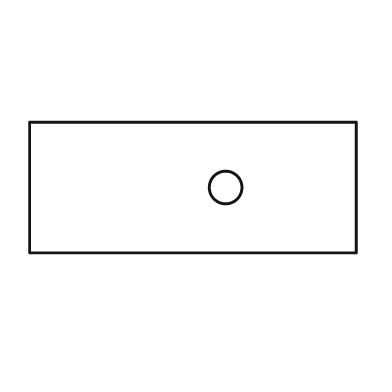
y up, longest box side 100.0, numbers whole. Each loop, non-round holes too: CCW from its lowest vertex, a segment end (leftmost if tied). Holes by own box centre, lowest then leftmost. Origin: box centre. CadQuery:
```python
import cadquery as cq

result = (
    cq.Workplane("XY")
    .moveTo(-50.0, -20.0)
    .lineTo(50.0, -20.0)
    .lineTo(50.0, 20.0)
    .lineTo(-50.0, 20.0)
    .close()
    .moveTo(10.0, 0.0)
    .circle(5.0)
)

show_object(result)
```